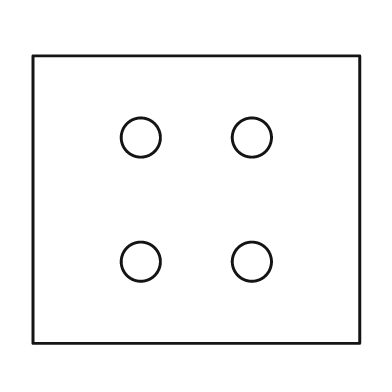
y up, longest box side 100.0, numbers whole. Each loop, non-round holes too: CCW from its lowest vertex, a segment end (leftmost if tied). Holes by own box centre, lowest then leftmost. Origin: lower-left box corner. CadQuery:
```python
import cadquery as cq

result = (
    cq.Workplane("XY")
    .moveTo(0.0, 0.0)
    .lineTo(100.0, 0.0)
    .lineTo(100.0, 88.0)
    .lineTo(0.0, 88.0)
    .close()
    .moveTo(33.0, 25.0)
    .circle(6.0)
    .moveTo(67.0, 25.0)
    .circle(6.0)
    .moveTo(33.0, 63.0)
    .circle(6.0)
    .moveTo(67.0, 63.0)
    .circle(6.0)
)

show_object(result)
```